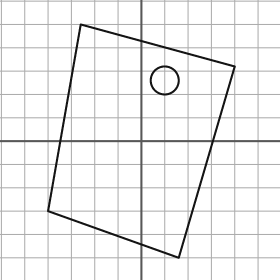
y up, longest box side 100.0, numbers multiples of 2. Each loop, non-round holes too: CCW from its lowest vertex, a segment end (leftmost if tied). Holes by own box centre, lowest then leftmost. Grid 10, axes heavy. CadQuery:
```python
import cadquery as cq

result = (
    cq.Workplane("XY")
    .moveTo(16.0, -50.0)
    .lineTo(40.0, 32.0)
    .lineTo(-26.0, 50.0)
    .lineTo(-40.0, -30.0)
    .close()
    .moveTo(10.0, 26.0)
    .circle(6.0)
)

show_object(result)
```